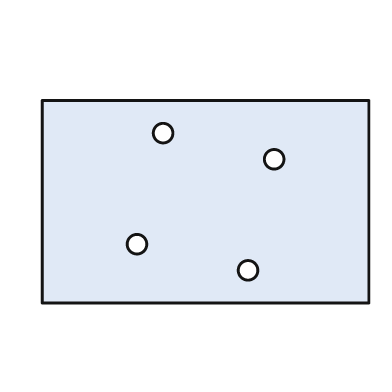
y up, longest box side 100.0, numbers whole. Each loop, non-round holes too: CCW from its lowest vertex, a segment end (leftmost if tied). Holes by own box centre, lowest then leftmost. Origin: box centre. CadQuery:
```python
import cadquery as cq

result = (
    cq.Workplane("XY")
    .moveTo(-50.0, -31.0)
    .lineTo(50.0, -31.0)
    .lineTo(50.0, 31.0)
    .lineTo(-50.0, 31.0)
    .close()
    .moveTo(13.0, -21.0)
    .circle(3.0)
    .moveTo(-21.0, -13.0)
    .circle(3.0)
    .moveTo(21.0, 13.0)
    .circle(3.0)
    .moveTo(-13.0, 21.0)
    .circle(3.0)
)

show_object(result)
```